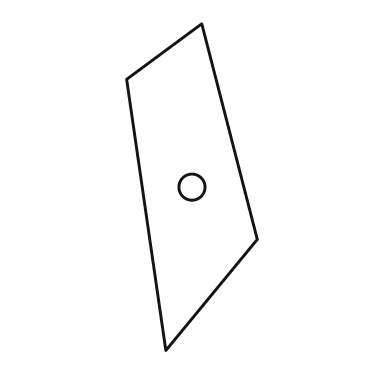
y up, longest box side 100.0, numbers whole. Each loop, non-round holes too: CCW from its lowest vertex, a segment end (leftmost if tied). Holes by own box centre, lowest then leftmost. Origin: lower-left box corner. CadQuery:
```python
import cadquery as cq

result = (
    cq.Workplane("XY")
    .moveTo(12.0, 0.0)
    .lineTo(40.0, 34.0)
    .lineTo(23.0, 100.0)
    .lineTo(0.0, 83.0)
    .close()
    .moveTo(20.0, 50.0)
    .circle(4.0)
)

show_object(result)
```